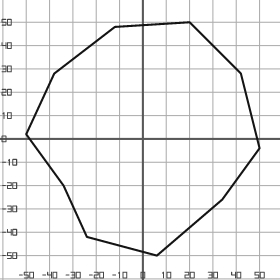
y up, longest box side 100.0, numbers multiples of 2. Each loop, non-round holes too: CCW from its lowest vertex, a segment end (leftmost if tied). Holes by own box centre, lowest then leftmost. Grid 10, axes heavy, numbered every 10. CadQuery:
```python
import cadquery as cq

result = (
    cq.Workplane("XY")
    .moveTo(6.0, -50.0)
    .lineTo(34.0, -26.0)
    .lineTo(50.0, -4.0)
    .lineTo(42.0, 28.0)
    .lineTo(20.0, 50.0)
    .lineTo(-12.0, 48.0)
    .lineTo(-38.0, 28.0)
    .lineTo(-50.0, 2.0)
    .lineTo(-34.0, -20.0)
    .lineTo(-24.0, -42.0)
    .close()
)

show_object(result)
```